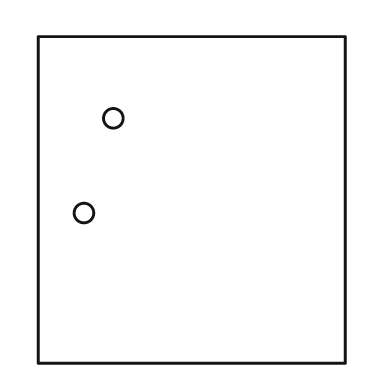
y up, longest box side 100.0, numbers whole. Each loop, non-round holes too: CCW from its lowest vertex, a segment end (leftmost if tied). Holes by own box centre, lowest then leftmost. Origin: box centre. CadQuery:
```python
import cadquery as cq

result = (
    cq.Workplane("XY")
    .moveTo(-47.0, -50.0)
    .lineTo(47.0, -50.0)
    .lineTo(47.0, 50.0)
    .lineTo(-47.0, 50.0)
    .close()
    .moveTo(-33.0, -4.0)
    .circle(3.0)
    .moveTo(-24.0, 25.0)
    .circle(3.0)
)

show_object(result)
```